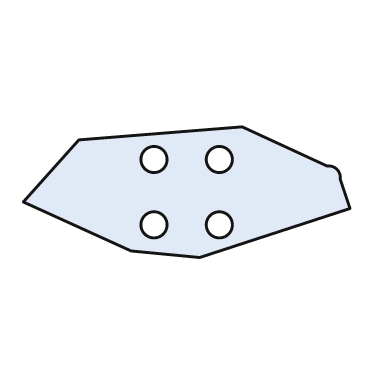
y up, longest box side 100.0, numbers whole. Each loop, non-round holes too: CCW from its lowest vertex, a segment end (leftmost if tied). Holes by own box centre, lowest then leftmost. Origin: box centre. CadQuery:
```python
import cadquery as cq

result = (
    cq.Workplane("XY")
    .moveTo(4.0, -20.0)
    .lineTo(50.0, -5.0)
    .lineTo(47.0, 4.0)
    .threePointArc((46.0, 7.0), (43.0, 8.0))
    .lineTo(17.0, 20.0)
    .lineTo(-33.0, 16.0)
    .lineTo(-50.0, -3.0)
    .lineTo(-17.0, -18.0)
    .close()
    .moveTo(-10.0, -10.0)
    .circle(4.0)
    .moveTo(10.0, -10.0)
    .circle(4.0)
    .moveTo(-10.0, 10.0)
    .circle(4.0)
    .moveTo(10.0, 10.0)
    .circle(4.0)
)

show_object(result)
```